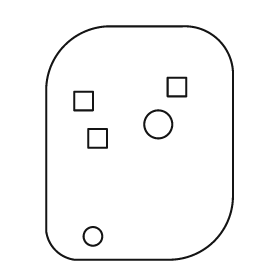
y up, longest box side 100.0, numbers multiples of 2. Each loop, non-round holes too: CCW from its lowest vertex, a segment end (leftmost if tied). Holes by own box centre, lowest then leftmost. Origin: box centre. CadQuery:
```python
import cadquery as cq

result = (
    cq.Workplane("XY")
    .moveTo(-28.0, -50.0)
    .lineTo(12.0, -50.0)
    .threePointArc((32.0, -42.0), (40.0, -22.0))
    .lineTo(40.0, 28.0)
    .threePointArc((34.0, 44.0), (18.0, 50.0))
    .lineTo(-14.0, 50.0)
    .threePointArc((-32.0, 42.0), (-40.0, 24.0))
    .lineTo(-40.0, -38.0)
    .threePointArc((-36.0, -46.0), (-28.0, -50.0))
    .close()
    .moveTo(-20.0, -40.0)
    .circle(4.0)
    .moveTo(-22.0, -2.0)
    .lineTo(-14.0, -2.0)
    .lineTo(-14.0, 6.0)
    .lineTo(-22.0, 6.0)
    .close()
    .moveTo(8.0, 8.0)
    .circle(6.0)
    .moveTo(-28.0, 14.0)
    .lineTo(-20.0, 14.0)
    .lineTo(-20.0, 22.0)
    .lineTo(-28.0, 22.0)
    .close()
    .moveTo(12.0, 20.0)
    .lineTo(20.0, 20.0)
    .lineTo(20.0, 28.0)
    .lineTo(12.0, 28.0)
    .close()
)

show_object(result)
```